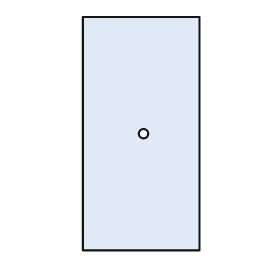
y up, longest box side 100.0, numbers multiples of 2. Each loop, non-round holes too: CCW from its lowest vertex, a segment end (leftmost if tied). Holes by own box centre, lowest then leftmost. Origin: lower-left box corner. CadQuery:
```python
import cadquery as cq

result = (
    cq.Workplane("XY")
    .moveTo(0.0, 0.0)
    .lineTo(50.0, 0.0)
    .lineTo(50.0, 100.0)
    .lineTo(0.0, 100.0)
    .close()
    .moveTo(26.0, 50.0)
    .circle(2.0)
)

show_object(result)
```